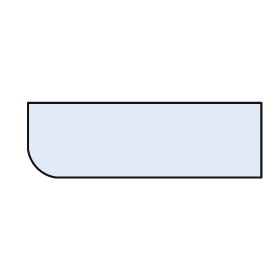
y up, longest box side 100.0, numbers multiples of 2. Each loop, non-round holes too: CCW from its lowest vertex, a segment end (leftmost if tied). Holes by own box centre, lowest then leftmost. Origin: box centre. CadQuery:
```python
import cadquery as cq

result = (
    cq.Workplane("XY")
    .moveTo(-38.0, -16.0)
    .lineTo(50.0, -16.0)
    .lineTo(50.0, 16.0)
    .lineTo(-50.0, 16.0)
    .lineTo(-50.0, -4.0)
    .threePointArc((-46.0, -12.0), (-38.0, -16.0))
    .close()
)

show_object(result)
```